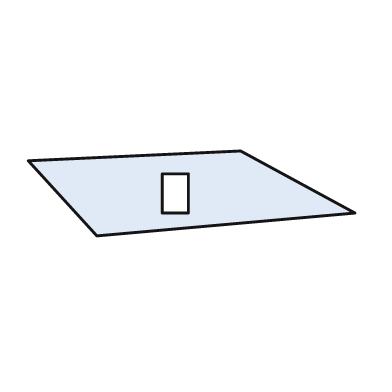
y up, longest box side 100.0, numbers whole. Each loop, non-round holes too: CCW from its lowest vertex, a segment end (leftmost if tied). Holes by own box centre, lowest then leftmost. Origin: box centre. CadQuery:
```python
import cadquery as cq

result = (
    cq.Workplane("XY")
    .moveTo(-29.0, -13.0)
    .lineTo(50.0, -6.0)
    .lineTo(15.0, 13.0)
    .lineTo(-50.0, 10.0)
    .close()
    .moveTo(-9.0, -6.0)
    .lineTo(-1.0, -6.0)
    .lineTo(-1.0, 6.0)
    .lineTo(-9.0, 6.0)
    .close()
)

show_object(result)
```